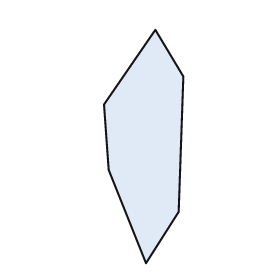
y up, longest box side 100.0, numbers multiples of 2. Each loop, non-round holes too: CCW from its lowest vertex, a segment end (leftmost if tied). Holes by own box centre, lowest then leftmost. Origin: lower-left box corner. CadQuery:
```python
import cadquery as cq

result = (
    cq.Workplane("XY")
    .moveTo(18.0, 0.0)
    .lineTo(32.0, 22.0)
    .lineTo(34.0, 80.0)
    .lineTo(22.0, 100.0)
    .lineTo(0.0, 68.0)
    .lineTo(2.0, 40.0)
    .close()
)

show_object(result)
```